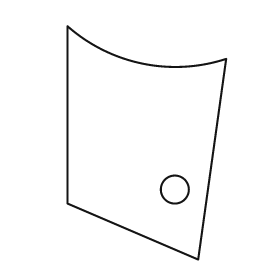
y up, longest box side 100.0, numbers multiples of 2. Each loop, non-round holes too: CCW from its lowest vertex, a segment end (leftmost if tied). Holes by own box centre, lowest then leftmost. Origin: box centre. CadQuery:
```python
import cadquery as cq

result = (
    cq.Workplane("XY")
    .moveTo(22.0, -50.0)
    .lineTo(34.0, 36.0)
    .threePointArc((-2.0, 34.0), (-34.0, 50.0))
    .lineTo(-34.0, -26.0)
    .close()
    .moveTo(12.0, -20.0)
    .circle(6.0)
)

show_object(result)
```